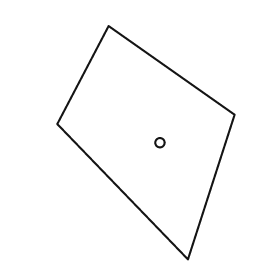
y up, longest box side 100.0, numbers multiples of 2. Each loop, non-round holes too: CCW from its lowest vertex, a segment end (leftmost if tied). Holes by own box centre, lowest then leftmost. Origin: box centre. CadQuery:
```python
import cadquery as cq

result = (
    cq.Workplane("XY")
    .moveTo(18.0, -50.0)
    .lineTo(38.0, 12.0)
    .lineTo(-16.0, 50.0)
    .lineTo(-38.0, 8.0)
    .close()
    .moveTo(6.0, 0.0)
    .circle(2.0)
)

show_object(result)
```